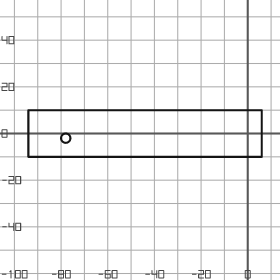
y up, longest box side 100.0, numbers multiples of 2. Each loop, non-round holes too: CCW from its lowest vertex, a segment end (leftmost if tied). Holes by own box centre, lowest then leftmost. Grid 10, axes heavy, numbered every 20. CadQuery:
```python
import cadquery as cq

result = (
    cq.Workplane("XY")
    .moveTo(-94.0, -10.0)
    .lineTo(6.0, -10.0)
    .lineTo(6.0, 10.0)
    .lineTo(-94.0, 10.0)
    .close()
    .moveTo(-78.0, -2.0)
    .circle(2.0)
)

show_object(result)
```